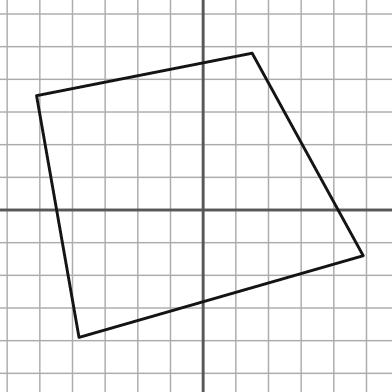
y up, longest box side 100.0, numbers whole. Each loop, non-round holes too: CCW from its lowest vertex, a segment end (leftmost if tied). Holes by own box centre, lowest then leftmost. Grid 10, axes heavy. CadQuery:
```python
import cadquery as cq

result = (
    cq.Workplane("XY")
    .moveTo(-38.0, -39.0)
    .lineTo(49.0, -14.0)
    .lineTo(15.0, 48.0)
    .lineTo(-51.0, 35.0)
    .close()
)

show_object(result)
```